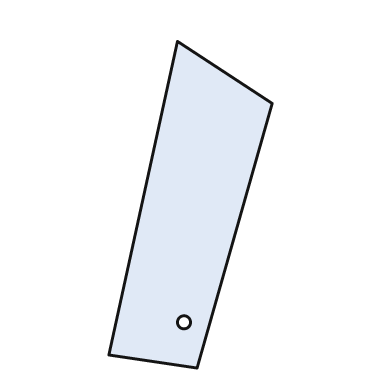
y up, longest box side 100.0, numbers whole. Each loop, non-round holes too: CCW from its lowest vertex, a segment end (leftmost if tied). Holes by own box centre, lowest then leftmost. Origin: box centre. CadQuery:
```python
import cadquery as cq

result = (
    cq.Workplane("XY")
    .moveTo(2.0, -50.0)
    .lineTo(25.0, 31.0)
    .lineTo(-4.0, 50.0)
    .lineTo(-25.0, -46.0)
    .close()
    .moveTo(-2.0, -36.0)
    .circle(2.0)
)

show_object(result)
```